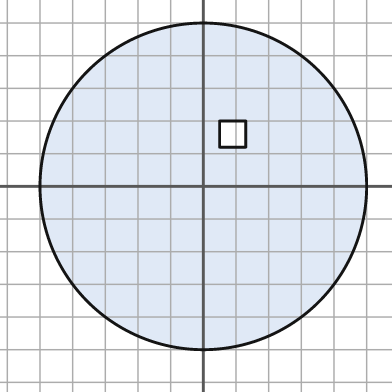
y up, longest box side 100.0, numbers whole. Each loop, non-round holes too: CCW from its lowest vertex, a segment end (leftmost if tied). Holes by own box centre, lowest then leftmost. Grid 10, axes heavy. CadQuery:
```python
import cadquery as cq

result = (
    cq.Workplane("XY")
    .moveTo(0.0, 0.0)
    .circle(50.0)
    .moveTo(5.0, 12.0)
    .lineTo(13.0, 12.0)
    .lineTo(13.0, 20.0)
    .lineTo(5.0, 20.0)
    .close()
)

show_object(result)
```